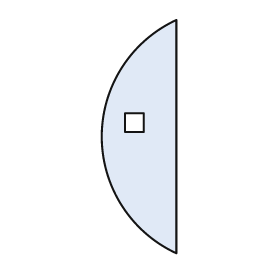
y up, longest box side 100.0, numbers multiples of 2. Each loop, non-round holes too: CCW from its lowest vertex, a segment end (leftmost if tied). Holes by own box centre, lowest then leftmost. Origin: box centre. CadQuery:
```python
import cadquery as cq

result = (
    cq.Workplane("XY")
    .moveTo(16.0, -50.0)
    .lineTo(16.0, 50.0)
    .threePointArc((-16.0, 0.0), (16.0, -50.0))
    .close()
    .moveTo(-6.0, 2.0)
    .lineTo(2.0, 2.0)
    .lineTo(2.0, 10.0)
    .lineTo(-6.0, 10.0)
    .close()
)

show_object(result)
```